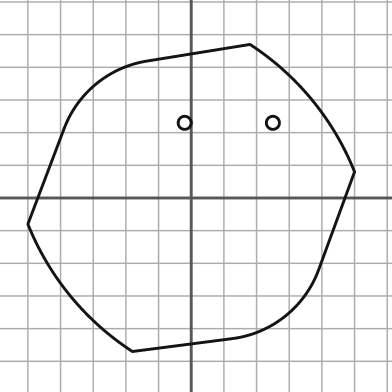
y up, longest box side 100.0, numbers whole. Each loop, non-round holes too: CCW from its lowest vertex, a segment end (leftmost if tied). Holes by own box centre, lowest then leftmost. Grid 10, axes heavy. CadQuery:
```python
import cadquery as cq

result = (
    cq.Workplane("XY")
    .moveTo(-18.0, -47.0)
    .lineTo(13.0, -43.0)
    .threePointArc((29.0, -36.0), (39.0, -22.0))
    .lineTo(50.0, 8.0)
    .threePointArc((37.0, 30.0), (18.0, 47.0))
    .lineTo(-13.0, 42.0)
    .threePointArc((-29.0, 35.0), (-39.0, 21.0))
    .lineTo(-50.0, -8.0)
    .threePointArc((-37.0, -30.0), (-18.0, -47.0))
    .close()
    .moveTo(-2.0, 23.0)
    .circle(2.0)
    .moveTo(25.0, 23.0)
    .circle(2.0)
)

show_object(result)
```